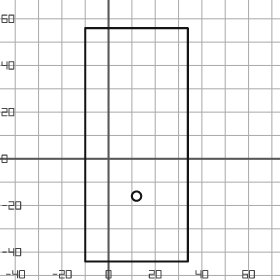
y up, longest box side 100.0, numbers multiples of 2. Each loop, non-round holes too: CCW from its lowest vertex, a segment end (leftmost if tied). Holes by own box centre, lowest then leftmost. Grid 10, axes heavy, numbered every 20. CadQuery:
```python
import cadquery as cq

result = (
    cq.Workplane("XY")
    .moveTo(-10.0, -44.0)
    .lineTo(34.0, -44.0)
    .lineTo(34.0, 56.0)
    .lineTo(-10.0, 56.0)
    .close()
    .moveTo(12.0, -16.0)
    .circle(2.0)
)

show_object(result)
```